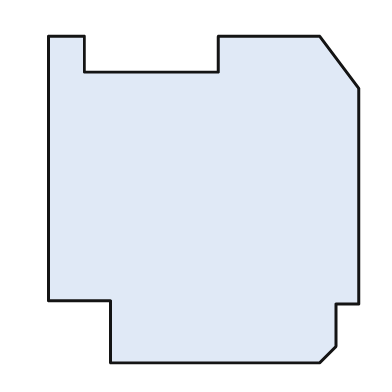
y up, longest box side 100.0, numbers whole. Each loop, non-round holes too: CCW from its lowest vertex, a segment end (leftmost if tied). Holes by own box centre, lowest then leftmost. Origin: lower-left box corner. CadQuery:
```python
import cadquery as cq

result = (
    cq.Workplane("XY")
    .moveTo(19.0, 0.0)
    .lineTo(83.0, 0.0)
    .lineTo(88.0, 5.0)
    .lineTo(88.0, 18.0)
    .lineTo(95.0, 18.0)
    .lineTo(95.0, 84.0)
    .lineTo(83.0, 100.0)
    .lineTo(52.0, 100.0)
    .lineTo(52.0, 89.0)
    .lineTo(11.0, 89.0)
    .lineTo(11.0, 100.0)
    .lineTo(0.0, 100.0)
    .lineTo(0.0, 19.0)
    .lineTo(19.0, 19.0)
    .close()
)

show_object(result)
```